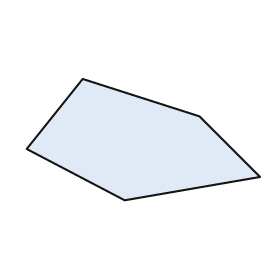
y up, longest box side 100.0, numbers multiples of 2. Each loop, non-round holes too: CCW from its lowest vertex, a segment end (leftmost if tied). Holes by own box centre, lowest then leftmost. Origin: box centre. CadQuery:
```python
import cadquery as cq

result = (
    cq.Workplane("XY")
    .moveTo(-8.0, -26.0)
    .lineTo(50.0, -16.0)
    .lineTo(24.0, 10.0)
    .lineTo(-26.0, 26.0)
    .lineTo(-50.0, -4.0)
    .close()
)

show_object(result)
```